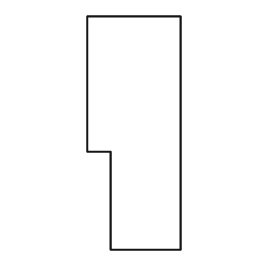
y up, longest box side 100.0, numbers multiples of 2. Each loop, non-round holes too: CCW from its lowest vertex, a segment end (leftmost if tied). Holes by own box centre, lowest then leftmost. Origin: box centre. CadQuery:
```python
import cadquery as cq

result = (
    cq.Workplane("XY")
    .moveTo(-10.0, -50.0)
    .lineTo(20.0, -50.0)
    .lineTo(20.0, 50.0)
    .lineTo(-20.0, 50.0)
    .lineTo(-20.0, -8.0)
    .lineTo(-10.0, -8.0)
    .close()
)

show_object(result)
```